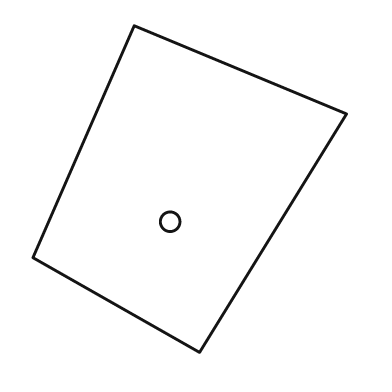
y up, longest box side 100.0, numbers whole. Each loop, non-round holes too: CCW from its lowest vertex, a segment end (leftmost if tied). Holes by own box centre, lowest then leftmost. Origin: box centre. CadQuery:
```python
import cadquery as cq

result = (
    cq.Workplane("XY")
    .moveTo(3.0, -50.0)
    .lineTo(48.0, 23.0)
    .lineTo(-17.0, 50.0)
    .lineTo(-48.0, -21.0)
    .close()
    .moveTo(-6.0, -10.0)
    .circle(3.0)
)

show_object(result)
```